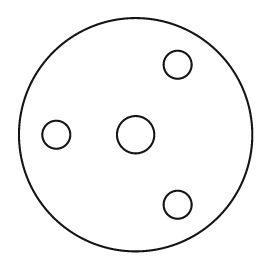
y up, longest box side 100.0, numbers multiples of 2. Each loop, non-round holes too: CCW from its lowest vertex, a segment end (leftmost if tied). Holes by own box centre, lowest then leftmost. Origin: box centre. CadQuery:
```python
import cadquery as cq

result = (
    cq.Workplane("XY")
    .moveTo(0.0, 0.0)
    .circle(50.0)
    .moveTo(18.0, -30.0)
    .circle(6.0)
    .moveTo(-34.0, 0.0)
    .circle(6.0)
    .moveTo(0.0, 0.0)
    .circle(8.0)
    .moveTo(18.0, 30.0)
    .circle(6.0)
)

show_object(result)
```